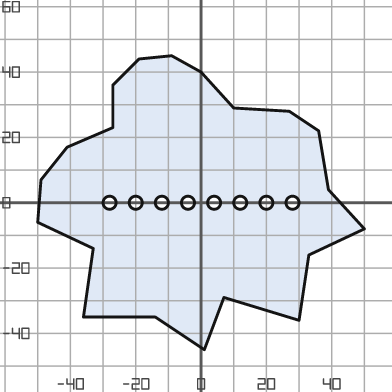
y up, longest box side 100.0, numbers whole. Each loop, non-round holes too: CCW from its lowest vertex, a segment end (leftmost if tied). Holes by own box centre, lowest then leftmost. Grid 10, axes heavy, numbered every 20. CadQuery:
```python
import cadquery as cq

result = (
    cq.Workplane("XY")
    .moveTo(1.0, -45.0)
    .lineTo(7.0, -29.0)
    .lineTo(30.0, -36.0)
    .lineTo(33.0, -16.0)
    .lineTo(50.0, -8.0)
    .lineTo(39.0, 4.0)
    .lineTo(36.0, 22.0)
    .lineTo(27.0, 28.0)
    .lineTo(10.0, 29.0)
    .lineTo(0.0, 40.0)
    .lineTo(-9.0, 45.0)
    .lineTo(-19.0, 44.0)
    .lineTo(-27.0, 36.0)
    .lineTo(-27.0, 23.0)
    .lineTo(-41.0, 17.0)
    .lineTo(-49.0, 7.0)
    .lineTo(-50.0, -6.0)
    .lineTo(-33.0, -14.0)
    .lineTo(-36.0, -35.0)
    .lineTo(-14.0, -35.0)
    .close()
    .moveTo(-28.0, 0.0)
    .circle(2.0)
    .moveTo(-20.0, 0.0)
    .circle(2.0)
    .moveTo(-12.0, 0.0)
    .circle(2.0)
    .moveTo(-4.0, 0.0)
    .circle(2.0)
    .moveTo(4.0, 0.0)
    .circle(2.0)
    .moveTo(12.0, 0.0)
    .circle(2.0)
    .moveTo(20.0, 0.0)
    .circle(2.0)
    .moveTo(28.0, 0.0)
    .circle(2.0)
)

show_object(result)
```